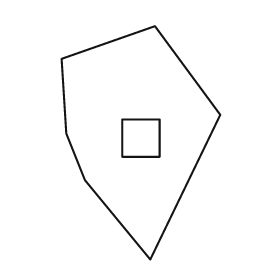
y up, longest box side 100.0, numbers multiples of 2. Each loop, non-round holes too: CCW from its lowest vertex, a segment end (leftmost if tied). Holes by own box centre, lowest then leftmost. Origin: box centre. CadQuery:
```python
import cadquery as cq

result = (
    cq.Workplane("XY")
    .moveTo(4.0, -50.0)
    .lineTo(34.0, 12.0)
    .lineTo(6.0, 50.0)
    .lineTo(-34.0, 36.0)
    .lineTo(-32.0, 4.0)
    .lineTo(-24.0, -16.0)
    .close()
    .moveTo(-8.0, -6.0)
    .lineTo(8.0, -6.0)
    .lineTo(8.0, 10.0)
    .lineTo(-8.0, 10.0)
    .close()
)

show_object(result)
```